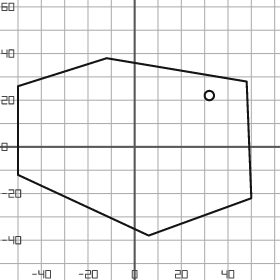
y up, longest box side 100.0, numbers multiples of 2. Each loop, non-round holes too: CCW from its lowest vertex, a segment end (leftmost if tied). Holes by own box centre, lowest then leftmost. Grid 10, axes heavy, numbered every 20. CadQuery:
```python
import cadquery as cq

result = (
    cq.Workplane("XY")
    .moveTo(6.0, -38.0)
    .lineTo(50.0, -22.0)
    .lineTo(48.0, 28.0)
    .lineTo(-12.0, 38.0)
    .lineTo(-50.0, 26.0)
    .lineTo(-50.0, -12.0)
    .close()
    .moveTo(32.0, 22.0)
    .circle(2.0)
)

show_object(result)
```